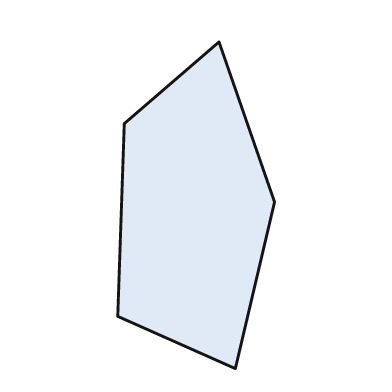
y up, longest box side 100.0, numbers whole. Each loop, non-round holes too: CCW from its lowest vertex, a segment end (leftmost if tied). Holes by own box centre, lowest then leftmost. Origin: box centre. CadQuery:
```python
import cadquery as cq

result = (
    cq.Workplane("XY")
    .moveTo(12.0, -50.0)
    .lineTo(24.0, 1.0)
    .lineTo(7.0, 50.0)
    .lineTo(-22.0, 25.0)
    .lineTo(-24.0, -34.0)
    .close()
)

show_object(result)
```